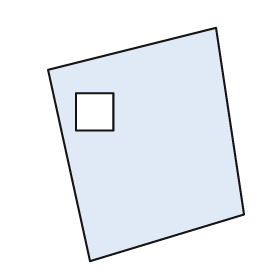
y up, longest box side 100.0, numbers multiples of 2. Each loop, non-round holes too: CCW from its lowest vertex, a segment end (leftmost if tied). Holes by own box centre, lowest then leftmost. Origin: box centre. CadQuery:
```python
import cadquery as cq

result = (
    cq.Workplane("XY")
    .moveTo(-24.0, -50.0)
    .lineTo(42.0, -30.0)
    .lineTo(30.0, 50.0)
    .lineTo(-42.0, 32.0)
    .close()
    .moveTo(-30.0, 6.0)
    .lineTo(-14.0, 6.0)
    .lineTo(-14.0, 22.0)
    .lineTo(-30.0, 22.0)
    .close()
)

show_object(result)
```